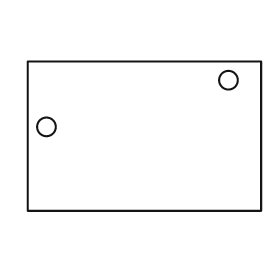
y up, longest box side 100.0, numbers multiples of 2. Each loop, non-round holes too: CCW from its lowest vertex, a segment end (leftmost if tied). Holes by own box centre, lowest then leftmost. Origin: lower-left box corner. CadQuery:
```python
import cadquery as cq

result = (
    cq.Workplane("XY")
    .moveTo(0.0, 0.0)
    .lineTo(100.0, 0.0)
    .lineTo(100.0, 64.0)
    .lineTo(0.0, 64.0)
    .close()
    .moveTo(8.0, 36.0)
    .circle(4.0)
    .moveTo(86.0, 56.0)
    .circle(4.0)
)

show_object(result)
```